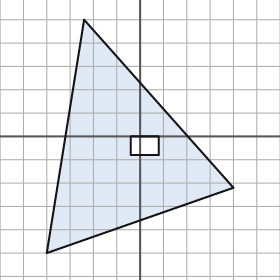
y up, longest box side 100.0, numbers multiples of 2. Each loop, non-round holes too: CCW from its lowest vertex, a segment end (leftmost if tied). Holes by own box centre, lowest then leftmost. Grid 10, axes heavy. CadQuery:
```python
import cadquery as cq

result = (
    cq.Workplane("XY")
    .moveTo(-40.0, -50.0)
    .lineTo(40.0, -22.0)
    .lineTo(-24.0, 50.0)
    .close()
    .moveTo(-4.0, -8.0)
    .lineTo(8.0, -8.0)
    .lineTo(8.0, 0.0)
    .lineTo(-4.0, 0.0)
    .close()
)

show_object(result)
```